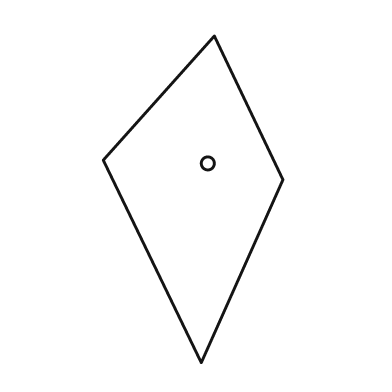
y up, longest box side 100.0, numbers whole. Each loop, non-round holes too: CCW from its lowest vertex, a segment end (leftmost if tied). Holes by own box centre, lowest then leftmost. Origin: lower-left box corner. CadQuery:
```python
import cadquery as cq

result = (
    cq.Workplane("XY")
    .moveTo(30.0, 0.0)
    .lineTo(55.0, 56.0)
    .lineTo(34.0, 100.0)
    .lineTo(0.0, 62.0)
    .close()
    .moveTo(32.0, 61.0)
    .circle(2.0)
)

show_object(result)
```